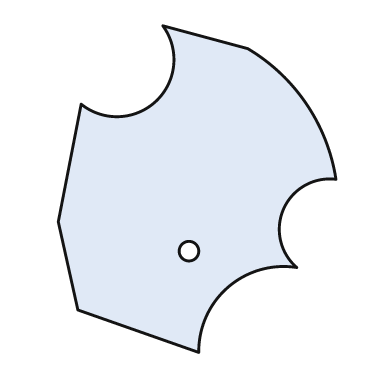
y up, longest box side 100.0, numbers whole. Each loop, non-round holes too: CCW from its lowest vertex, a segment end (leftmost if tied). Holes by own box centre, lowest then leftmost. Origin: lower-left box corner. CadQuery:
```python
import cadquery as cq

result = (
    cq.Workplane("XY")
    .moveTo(43.0, 0.0)
    .threePointArc((52.0, 20.0), (73.0, 26.0))
    .threePointArc((69.0, 44.0), (85.0, 53.0))
    .threePointArc((76.0, 76.0), (58.0, 93.0))
    .lineTo(32.0, 100.0)
    .threePointArc((30.0, 77.0), (7.0, 76.0))
    .lineTo(0.0, 40.0)
    .lineTo(6.0, 13.0)
    .close()
    .moveTo(40.0, 31.0)
    .circle(3.0)
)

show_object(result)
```